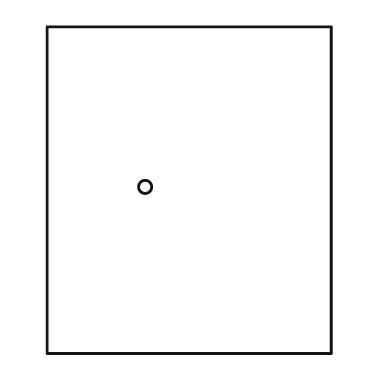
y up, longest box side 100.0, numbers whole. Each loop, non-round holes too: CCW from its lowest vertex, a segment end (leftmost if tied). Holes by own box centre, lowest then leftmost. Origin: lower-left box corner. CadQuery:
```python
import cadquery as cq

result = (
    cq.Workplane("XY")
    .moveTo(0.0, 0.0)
    .lineTo(87.0, 0.0)
    .lineTo(87.0, 100.0)
    .lineTo(0.0, 100.0)
    .close()
    .moveTo(30.0, 51.0)
    .circle(2.0)
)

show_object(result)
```